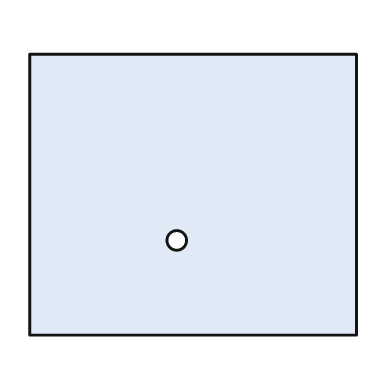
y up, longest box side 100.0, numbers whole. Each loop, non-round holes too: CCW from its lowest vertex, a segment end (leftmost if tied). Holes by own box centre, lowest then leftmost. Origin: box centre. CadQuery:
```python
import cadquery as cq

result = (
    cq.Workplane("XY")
    .moveTo(-50.0, -43.0)
    .lineTo(50.0, -43.0)
    .lineTo(50.0, 43.0)
    .lineTo(-50.0, 43.0)
    .close()
    .moveTo(-5.0, -14.0)
    .circle(3.0)
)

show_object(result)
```